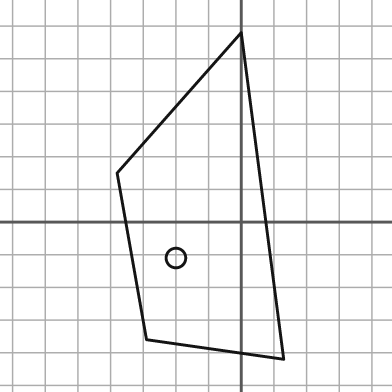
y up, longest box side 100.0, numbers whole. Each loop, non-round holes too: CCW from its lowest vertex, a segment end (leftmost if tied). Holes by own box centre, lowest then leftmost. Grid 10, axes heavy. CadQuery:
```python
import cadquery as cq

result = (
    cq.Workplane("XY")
    .moveTo(13.0, -42.0)
    .lineTo(0.0, 58.0)
    .lineTo(-38.0, 15.0)
    .lineTo(-29.0, -36.0)
    .close()
    .moveTo(-20.0, -11.0)
    .circle(3.0)
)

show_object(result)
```